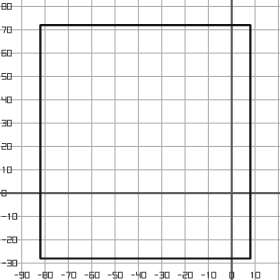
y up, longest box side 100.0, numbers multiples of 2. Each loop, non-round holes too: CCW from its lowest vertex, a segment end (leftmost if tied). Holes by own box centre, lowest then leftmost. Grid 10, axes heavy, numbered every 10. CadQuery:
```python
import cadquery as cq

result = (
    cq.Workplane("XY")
    .moveTo(-82.0, -28.0)
    .lineTo(8.0, -28.0)
    .lineTo(8.0, 72.0)
    .lineTo(-82.0, 72.0)
    .close()
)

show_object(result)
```